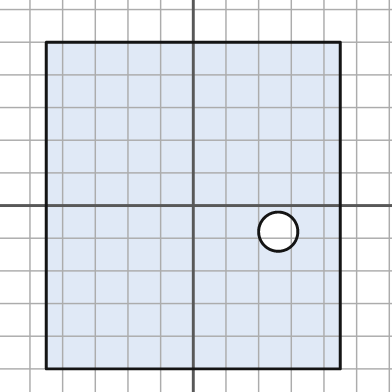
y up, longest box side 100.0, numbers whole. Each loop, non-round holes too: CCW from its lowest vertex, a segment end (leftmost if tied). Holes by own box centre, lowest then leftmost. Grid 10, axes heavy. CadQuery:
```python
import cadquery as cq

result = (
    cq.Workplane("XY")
    .moveTo(-45.0, -50.0)
    .lineTo(45.0, -50.0)
    .lineTo(45.0, 50.0)
    .lineTo(-45.0, 50.0)
    .close()
    .moveTo(26.0, -8.0)
    .circle(6.0)
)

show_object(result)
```